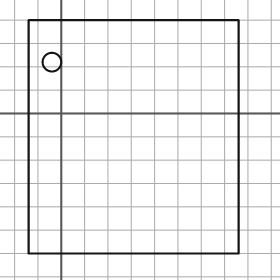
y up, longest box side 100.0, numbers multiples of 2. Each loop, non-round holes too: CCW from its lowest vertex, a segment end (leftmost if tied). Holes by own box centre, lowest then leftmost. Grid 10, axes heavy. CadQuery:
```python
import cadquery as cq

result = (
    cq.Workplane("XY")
    .moveTo(-14.0, -60.0)
    .lineTo(76.0, -60.0)
    .lineTo(76.0, 40.0)
    .lineTo(-14.0, 40.0)
    .close()
    .moveTo(-4.0, 22.0)
    .circle(4.0)
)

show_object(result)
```